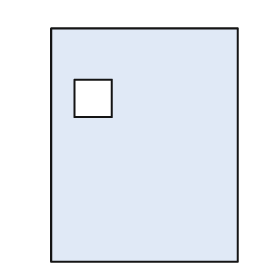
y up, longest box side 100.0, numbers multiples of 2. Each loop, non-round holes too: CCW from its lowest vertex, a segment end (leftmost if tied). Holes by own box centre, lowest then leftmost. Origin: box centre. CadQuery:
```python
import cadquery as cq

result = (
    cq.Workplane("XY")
    .moveTo(-40.0, -50.0)
    .lineTo(40.0, -50.0)
    .lineTo(40.0, 50.0)
    .lineTo(-40.0, 50.0)
    .close()
    .moveTo(-30.0, 12.0)
    .lineTo(-14.0, 12.0)
    .lineTo(-14.0, 28.0)
    .lineTo(-30.0, 28.0)
    .close()
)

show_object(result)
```